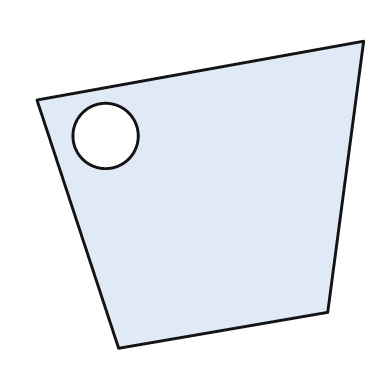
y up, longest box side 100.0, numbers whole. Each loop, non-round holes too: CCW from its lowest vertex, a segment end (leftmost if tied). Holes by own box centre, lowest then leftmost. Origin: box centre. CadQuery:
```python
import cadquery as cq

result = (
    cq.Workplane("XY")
    .moveTo(-25.0, -47.0)
    .lineTo(39.0, -36.0)
    .lineTo(50.0, 47.0)
    .lineTo(-50.0, 29.0)
    .close()
    .moveTo(-29.0, 18.0)
    .circle(10.0)
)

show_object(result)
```